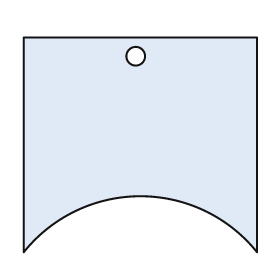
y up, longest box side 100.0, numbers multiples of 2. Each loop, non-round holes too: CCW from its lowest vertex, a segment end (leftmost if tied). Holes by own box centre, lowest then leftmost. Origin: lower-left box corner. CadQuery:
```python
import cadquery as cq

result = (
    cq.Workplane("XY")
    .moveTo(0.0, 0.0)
    .threePointArc((50.0, 24.0), (100.0, 0.0))
    .lineTo(100.0, 92.0)
    .lineTo(0.0, 92.0)
    .close()
    .moveTo(48.0, 84.0)
    .circle(4.0)
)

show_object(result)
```